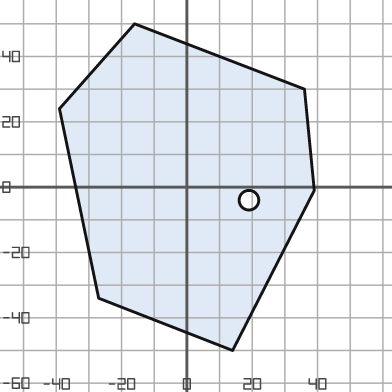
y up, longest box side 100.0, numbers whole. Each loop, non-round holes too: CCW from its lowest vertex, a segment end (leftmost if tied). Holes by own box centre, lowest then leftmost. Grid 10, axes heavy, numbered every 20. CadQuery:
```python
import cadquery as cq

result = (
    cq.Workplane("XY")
    .moveTo(14.0, -50.0)
    .lineTo(39.0, -1.0)
    .lineTo(36.0, 30.0)
    .lineTo(-16.0, 50.0)
    .lineTo(-39.0, 24.0)
    .lineTo(-27.0, -34.0)
    .close()
    .moveTo(19.0, -4.0)
    .circle(3.0)
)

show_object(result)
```